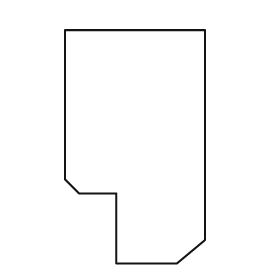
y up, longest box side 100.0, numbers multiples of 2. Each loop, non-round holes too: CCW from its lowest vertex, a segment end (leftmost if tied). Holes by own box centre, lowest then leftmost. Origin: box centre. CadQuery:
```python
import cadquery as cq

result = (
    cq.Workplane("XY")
    .moveTo(-8.0, -50.0)
    .lineTo(18.0, -50.0)
    .lineTo(30.0, -40.0)
    .lineTo(30.0, 50.0)
    .lineTo(-30.0, 50.0)
    .lineTo(-30.0, -14.0)
    .lineTo(-24.0, -20.0)
    .lineTo(-8.0, -20.0)
    .close()
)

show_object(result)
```